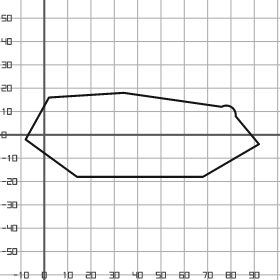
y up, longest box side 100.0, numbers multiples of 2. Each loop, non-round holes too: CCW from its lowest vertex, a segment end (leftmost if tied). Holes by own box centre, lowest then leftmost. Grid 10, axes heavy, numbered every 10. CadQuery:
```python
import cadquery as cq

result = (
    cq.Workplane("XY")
    .moveTo(14.0, -18.0)
    .lineTo(68.0, -18.0)
    .lineTo(92.0, -4.0)
    .lineTo(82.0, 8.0)
    .threePointArc((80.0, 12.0), (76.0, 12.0))
    .lineTo(34.0, 18.0)
    .lineTo(2.0, 16.0)
    .lineTo(-8.0, -2.0)
    .close()
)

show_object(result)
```